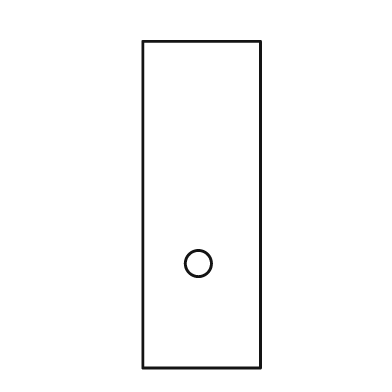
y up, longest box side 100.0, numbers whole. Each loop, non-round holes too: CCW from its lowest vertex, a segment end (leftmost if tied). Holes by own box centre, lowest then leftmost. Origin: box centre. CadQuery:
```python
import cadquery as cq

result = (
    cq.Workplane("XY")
    .moveTo(-18.0, -50.0)
    .lineTo(18.0, -50.0)
    .lineTo(18.0, 50.0)
    .lineTo(-18.0, 50.0)
    .close()
    .moveTo(-1.0, -18.0)
    .circle(4.0)
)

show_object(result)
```